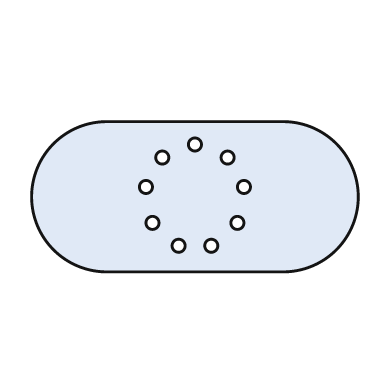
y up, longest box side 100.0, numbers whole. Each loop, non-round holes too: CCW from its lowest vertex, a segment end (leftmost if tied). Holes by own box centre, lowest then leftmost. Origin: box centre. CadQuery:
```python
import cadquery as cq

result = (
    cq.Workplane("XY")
    .moveTo(-27.0, -23.0)
    .lineTo(27.0, -23.0)
    .threePointArc((50.0, 0.0), (27.0, 23.0))
    .lineTo(-27.0, 23.0)
    .threePointArc((-50.0, 0.0), (-27.0, -23.0))
    .close()
    .moveTo(-5.0, -15.0)
    .circle(2.0)
    .moveTo(5.0, -15.0)
    .circle(2.0)
    .moveTo(-13.0, -8.0)
    .circle(2.0)
    .moveTo(13.0, -8.0)
    .circle(2.0)
    .moveTo(-15.0, 3.0)
    .circle(2.0)
    .moveTo(15.0, 3.0)
    .circle(2.0)
    .moveTo(-10.0, 12.0)
    .circle(2.0)
    .moveTo(10.0, 12.0)
    .circle(2.0)
    .moveTo(0.0, 16.0)
    .circle(2.0)
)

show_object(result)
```